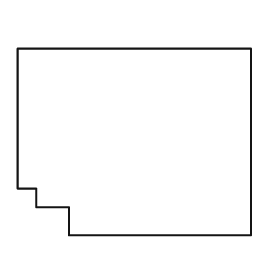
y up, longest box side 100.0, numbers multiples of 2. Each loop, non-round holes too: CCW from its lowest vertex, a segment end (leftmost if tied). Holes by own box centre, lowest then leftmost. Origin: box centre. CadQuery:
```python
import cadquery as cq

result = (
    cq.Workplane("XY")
    .moveTo(-28.0, -40.0)
    .lineTo(50.0, -40.0)
    .lineTo(50.0, 40.0)
    .lineTo(-50.0, 40.0)
    .lineTo(-50.0, -20.0)
    .lineTo(-42.0, -20.0)
    .lineTo(-42.0, -28.0)
    .lineTo(-28.0, -28.0)
    .close()
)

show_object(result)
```